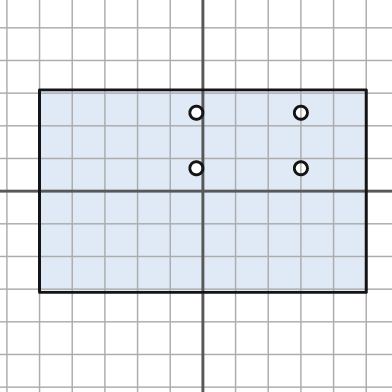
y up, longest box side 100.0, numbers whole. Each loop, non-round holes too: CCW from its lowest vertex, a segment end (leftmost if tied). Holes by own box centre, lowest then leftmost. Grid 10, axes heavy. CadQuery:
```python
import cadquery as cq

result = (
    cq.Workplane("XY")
    .moveTo(-50.0, -31.0)
    .lineTo(50.0, -31.0)
    .lineTo(50.0, 31.0)
    .lineTo(-50.0, 31.0)
    .close()
    .moveTo(-2.0, 7.0)
    .circle(2.0)
    .moveTo(30.0, 7.0)
    .circle(2.0)
    .moveTo(-2.0, 24.0)
    .circle(2.0)
    .moveTo(30.0, 24.0)
    .circle(2.0)
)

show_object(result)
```